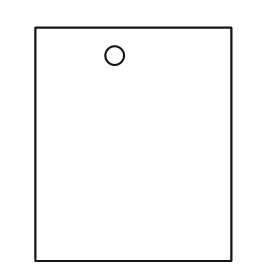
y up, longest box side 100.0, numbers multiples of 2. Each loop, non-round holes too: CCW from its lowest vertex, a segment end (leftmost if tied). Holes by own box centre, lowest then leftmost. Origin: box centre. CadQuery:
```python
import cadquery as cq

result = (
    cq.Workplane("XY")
    .moveTo(-42.0, -50.0)
    .lineTo(42.0, -50.0)
    .lineTo(42.0, 50.0)
    .lineTo(-42.0, 50.0)
    .close()
    .moveTo(-8.0, 38.0)
    .circle(4.0)
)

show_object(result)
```